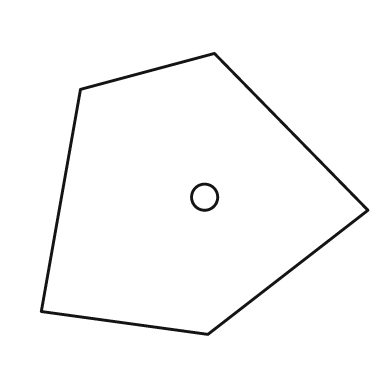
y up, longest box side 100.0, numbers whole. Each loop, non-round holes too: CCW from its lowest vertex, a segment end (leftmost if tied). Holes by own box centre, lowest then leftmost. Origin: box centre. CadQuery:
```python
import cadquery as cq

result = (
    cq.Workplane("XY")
    .moveTo(1.0, -43.0)
    .lineTo(50.0, -5.0)
    .lineTo(3.0, 43.0)
    .lineTo(-38.0, 32.0)
    .lineTo(-50.0, -36.0)
    .close()
    .moveTo(0.0, -1.0)
    .circle(4.0)
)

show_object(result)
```